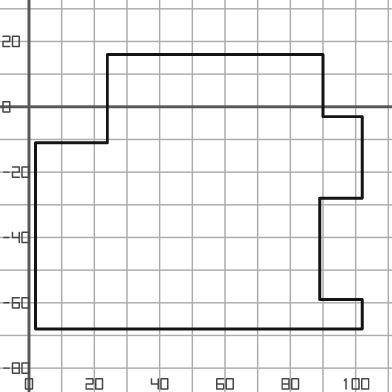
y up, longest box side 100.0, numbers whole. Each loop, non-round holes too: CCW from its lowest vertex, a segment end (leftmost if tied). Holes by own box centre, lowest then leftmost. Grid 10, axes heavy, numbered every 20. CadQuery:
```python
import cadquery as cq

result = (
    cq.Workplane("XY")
    .moveTo(2.0, -68.0)
    .lineTo(102.0, -68.0)
    .lineTo(102.0, -59.0)
    .lineTo(89.0, -59.0)
    .lineTo(89.0, -28.0)
    .lineTo(102.0, -28.0)
    .lineTo(102.0, -3.0)
    .lineTo(90.0, -3.0)
    .lineTo(90.0, 16.0)
    .lineTo(24.0, 16.0)
    .lineTo(24.0, -11.0)
    .lineTo(2.0, -11.0)
    .close()
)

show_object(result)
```